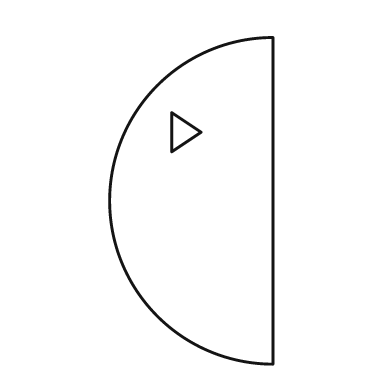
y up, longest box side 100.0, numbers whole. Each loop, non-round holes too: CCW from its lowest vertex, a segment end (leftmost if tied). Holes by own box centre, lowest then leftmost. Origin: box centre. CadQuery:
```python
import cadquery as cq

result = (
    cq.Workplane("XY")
    .moveTo(25.0, -50.0)
    .lineTo(25.0, 50.0)
    .threePointArc((-25.0, 0.0), (25.0, -50.0))
    .close()
    .moveTo(-6.0, 15.0)
    .lineTo(3.0, 21.0)
    .lineTo(-6.0, 27.0)
    .close()
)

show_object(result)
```